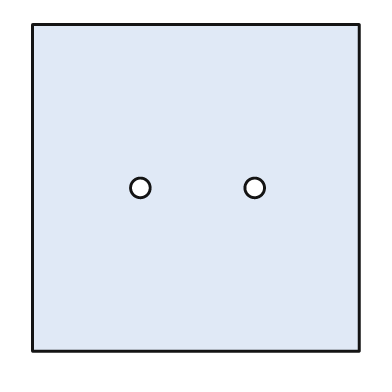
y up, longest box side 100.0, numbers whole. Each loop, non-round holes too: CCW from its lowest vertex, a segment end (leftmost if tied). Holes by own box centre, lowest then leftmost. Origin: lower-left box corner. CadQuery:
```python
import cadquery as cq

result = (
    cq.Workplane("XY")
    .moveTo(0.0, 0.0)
    .lineTo(100.0, 0.0)
    .lineTo(100.0, 100.0)
    .lineTo(0.0, 100.0)
    .close()
    .moveTo(33.0, 50.0)
    .circle(3.0)
    .moveTo(68.0, 50.0)
    .circle(3.0)
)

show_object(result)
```